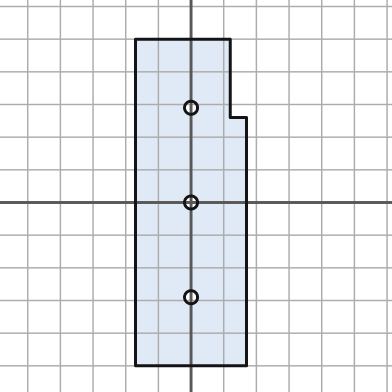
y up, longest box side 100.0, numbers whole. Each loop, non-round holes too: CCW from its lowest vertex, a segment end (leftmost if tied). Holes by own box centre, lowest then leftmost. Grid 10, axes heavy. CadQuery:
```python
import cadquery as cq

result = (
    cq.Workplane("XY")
    .moveTo(-17.0, -50.0)
    .lineTo(17.0, -50.0)
    .lineTo(17.0, 26.0)
    .lineTo(12.0, 26.0)
    .lineTo(12.0, 50.0)
    .lineTo(-17.0, 50.0)
    .close()
    .moveTo(0.0, -29.0)
    .circle(2.0)
    .moveTo(0.0, 0.0)
    .circle(2.0)
    .moveTo(0.0, 29.0)
    .circle(2.0)
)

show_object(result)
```